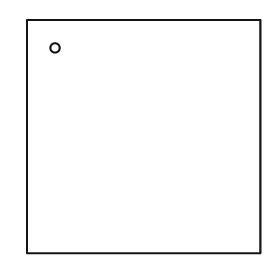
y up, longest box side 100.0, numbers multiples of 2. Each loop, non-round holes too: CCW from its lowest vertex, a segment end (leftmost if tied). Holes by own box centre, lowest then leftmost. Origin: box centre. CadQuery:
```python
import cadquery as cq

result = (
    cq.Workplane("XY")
    .moveTo(-50.0, -50.0)
    .lineTo(50.0, -50.0)
    .lineTo(50.0, 50.0)
    .lineTo(-50.0, 50.0)
    .close()
    .moveTo(-38.0, 38.0)
    .circle(2.0)
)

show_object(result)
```